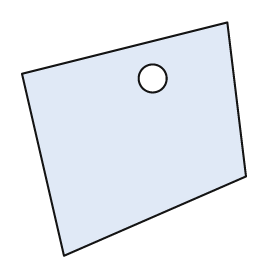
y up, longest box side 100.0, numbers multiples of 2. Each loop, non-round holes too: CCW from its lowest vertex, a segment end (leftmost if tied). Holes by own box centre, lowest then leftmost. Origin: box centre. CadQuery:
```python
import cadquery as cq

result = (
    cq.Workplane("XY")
    .moveTo(-30.0, -50.0)
    .lineTo(48.0, -16.0)
    .lineTo(40.0, 50.0)
    .lineTo(-48.0, 28.0)
    .close()
    .moveTo(8.0, 26.0)
    .circle(6.0)
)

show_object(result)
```